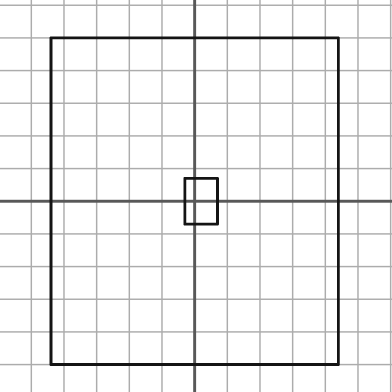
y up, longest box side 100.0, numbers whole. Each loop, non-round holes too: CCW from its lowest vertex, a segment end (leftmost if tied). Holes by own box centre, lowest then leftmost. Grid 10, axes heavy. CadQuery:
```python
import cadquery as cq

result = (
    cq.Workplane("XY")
    .moveTo(-44.0, -50.0)
    .lineTo(44.0, -50.0)
    .lineTo(44.0, 50.0)
    .lineTo(-44.0, 50.0)
    .close()
    .moveTo(-3.0, -7.0)
    .lineTo(7.0, -7.0)
    .lineTo(7.0, 7.0)
    .lineTo(-3.0, 7.0)
    .close()
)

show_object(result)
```